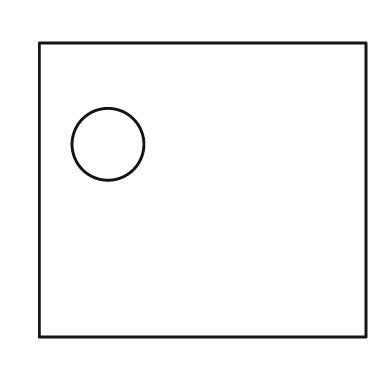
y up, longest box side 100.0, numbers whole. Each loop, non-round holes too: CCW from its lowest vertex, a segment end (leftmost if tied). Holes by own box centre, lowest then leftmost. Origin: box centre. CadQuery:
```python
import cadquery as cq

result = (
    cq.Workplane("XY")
    .moveTo(-50.0, -45.0)
    .lineTo(50.0, -45.0)
    .lineTo(50.0, 45.0)
    .lineTo(-50.0, 45.0)
    .close()
    .moveTo(-29.0, 14.0)
    .circle(11.0)
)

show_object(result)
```